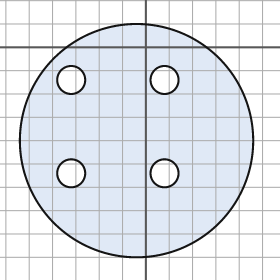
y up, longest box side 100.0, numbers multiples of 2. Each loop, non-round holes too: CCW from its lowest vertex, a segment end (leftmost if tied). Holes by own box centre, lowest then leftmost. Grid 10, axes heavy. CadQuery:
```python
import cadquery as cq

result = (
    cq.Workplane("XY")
    .moveTo(-4.0, -40.0)
    .circle(50.0)
    .moveTo(-32.0, -54.0)
    .circle(6.0)
    .moveTo(8.0, -54.0)
    .circle(6.0)
    .moveTo(-32.0, -14.0)
    .circle(6.0)
    .moveTo(8.0, -14.0)
    .circle(6.0)
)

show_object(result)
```